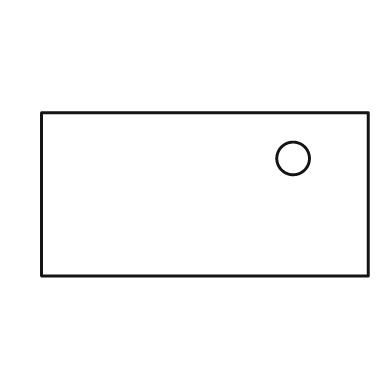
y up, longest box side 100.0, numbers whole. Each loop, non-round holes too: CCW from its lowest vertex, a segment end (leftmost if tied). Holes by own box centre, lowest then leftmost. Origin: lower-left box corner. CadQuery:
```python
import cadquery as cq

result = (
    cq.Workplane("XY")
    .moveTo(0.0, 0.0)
    .lineTo(100.0, 0.0)
    .lineTo(100.0, 50.0)
    .lineTo(0.0, 50.0)
    .close()
    .moveTo(77.0, 36.0)
    .circle(5.0)
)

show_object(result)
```